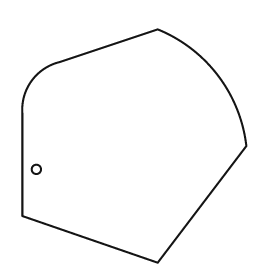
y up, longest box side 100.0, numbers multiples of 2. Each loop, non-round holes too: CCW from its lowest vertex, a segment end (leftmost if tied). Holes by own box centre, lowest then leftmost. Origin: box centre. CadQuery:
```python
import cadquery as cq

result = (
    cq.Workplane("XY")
    .moveTo(10.0, -50.0)
    .lineTo(48.0, 0.0)
    .threePointArc((36.0, 30.0), (10.0, 50.0))
    .lineTo(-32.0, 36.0)
    .threePointArc((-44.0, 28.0), (-48.0, 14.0))
    .lineTo(-48.0, -30.0)
    .close()
    .moveTo(-42.0, -10.0)
    .circle(2.0)
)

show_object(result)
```